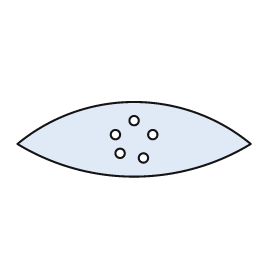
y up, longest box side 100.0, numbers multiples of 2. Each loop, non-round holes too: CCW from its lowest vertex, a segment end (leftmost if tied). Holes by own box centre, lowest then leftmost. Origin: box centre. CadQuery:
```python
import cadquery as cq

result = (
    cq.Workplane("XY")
    .moveTo(-50.0, -2.0)
    .threePointArc((0.0, -16.0), (50.0, -2.0))
    .threePointArc((0.0, 16.0), (-50.0, -2.0))
    .close()
    .moveTo(4.0, -8.0)
    .circle(2.0)
    .moveTo(-6.0, -6.0)
    .circle(2.0)
    .moveTo(-8.0, 2.0)
    .circle(2.0)
    .moveTo(8.0, 2.0)
    .circle(2.0)
    .moveTo(0.0, 8.0)
    .circle(2.0)
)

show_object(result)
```